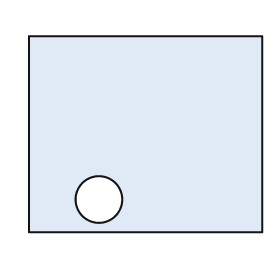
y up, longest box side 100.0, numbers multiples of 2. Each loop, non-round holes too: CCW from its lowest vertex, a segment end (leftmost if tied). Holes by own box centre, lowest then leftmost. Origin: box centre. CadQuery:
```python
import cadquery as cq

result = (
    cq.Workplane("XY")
    .moveTo(-50.0, -42.0)
    .lineTo(50.0, -42.0)
    .lineTo(50.0, 42.0)
    .lineTo(-50.0, 42.0)
    .close()
    .moveTo(-20.0, -28.0)
    .circle(10.0)
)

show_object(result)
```